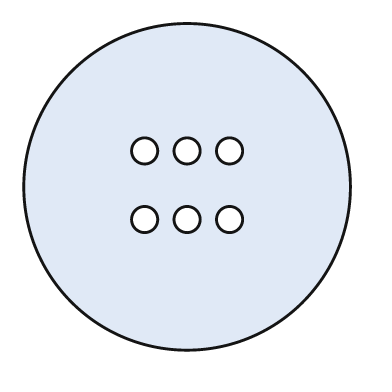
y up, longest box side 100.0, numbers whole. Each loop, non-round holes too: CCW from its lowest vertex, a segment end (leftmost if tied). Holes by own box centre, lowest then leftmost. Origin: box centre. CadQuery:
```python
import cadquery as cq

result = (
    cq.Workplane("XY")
    .moveTo(0.0, 0.0)
    .circle(50.0)
    .moveTo(-13.0, -10.0)
    .circle(4.0)
    .moveTo(0.0, -10.0)
    .circle(4.0)
    .moveTo(13.0, -10.0)
    .circle(4.0)
    .moveTo(-13.0, 11.0)
    .circle(4.0)
    .moveTo(0.0, 11.0)
    .circle(4.0)
    .moveTo(13.0, 11.0)
    .circle(4.0)
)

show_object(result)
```